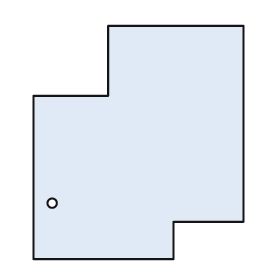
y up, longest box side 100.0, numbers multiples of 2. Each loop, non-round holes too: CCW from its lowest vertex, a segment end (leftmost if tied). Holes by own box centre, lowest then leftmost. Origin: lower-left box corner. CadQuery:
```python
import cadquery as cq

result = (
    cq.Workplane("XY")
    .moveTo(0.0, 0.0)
    .lineTo(60.0, 0.0)
    .lineTo(60.0, 16.0)
    .lineTo(90.0, 16.0)
    .lineTo(90.0, 100.0)
    .lineTo(32.0, 100.0)
    .lineTo(32.0, 70.0)
    .lineTo(0.0, 70.0)
    .close()
    .moveTo(8.0, 24.0)
    .circle(2.0)
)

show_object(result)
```